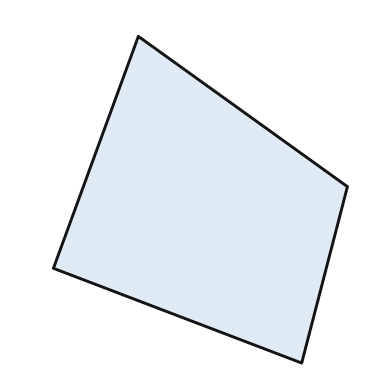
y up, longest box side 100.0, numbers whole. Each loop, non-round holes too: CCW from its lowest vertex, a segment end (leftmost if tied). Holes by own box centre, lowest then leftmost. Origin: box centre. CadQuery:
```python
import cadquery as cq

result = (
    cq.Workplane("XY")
    .moveTo(31.0, -50.0)
    .lineTo(45.0, 4.0)
    .lineTo(-19.0, 50.0)
    .lineTo(-45.0, -21.0)
    .close()
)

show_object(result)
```